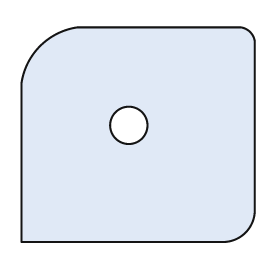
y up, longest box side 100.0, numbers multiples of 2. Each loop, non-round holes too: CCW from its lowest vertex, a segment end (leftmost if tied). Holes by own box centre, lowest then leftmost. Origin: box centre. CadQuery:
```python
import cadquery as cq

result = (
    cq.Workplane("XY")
    .moveTo(-50.0, -46.0)
    .lineTo(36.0, -46.0)
    .threePointArc((46.0, -42.0), (50.0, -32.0))
    .lineTo(50.0, 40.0)
    .threePointArc((48.0, 44.0), (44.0, 46.0))
    .lineTo(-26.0, 46.0)
    .threePointArc((-42.0, 38.0), (-50.0, 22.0))
    .close()
    .moveTo(-4.0, 4.0)
    .circle(8.0)
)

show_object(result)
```